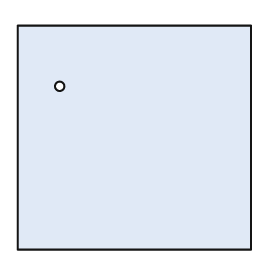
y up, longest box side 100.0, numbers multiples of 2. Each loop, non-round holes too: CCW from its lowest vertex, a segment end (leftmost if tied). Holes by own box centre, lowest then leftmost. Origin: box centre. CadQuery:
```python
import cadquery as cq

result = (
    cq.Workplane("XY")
    .moveTo(-50.0, -48.0)
    .lineTo(50.0, -48.0)
    .lineTo(50.0, 48.0)
    .lineTo(-50.0, 48.0)
    .close()
    .moveTo(-32.0, 22.0)
    .circle(2.0)
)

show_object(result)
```